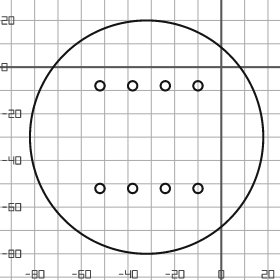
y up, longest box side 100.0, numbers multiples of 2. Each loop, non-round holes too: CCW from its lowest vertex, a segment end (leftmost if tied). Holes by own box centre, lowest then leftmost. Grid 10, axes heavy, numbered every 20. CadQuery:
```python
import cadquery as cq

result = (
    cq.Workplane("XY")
    .moveTo(-32.0, -30.0)
    .circle(50.0)
    .moveTo(-52.0, -52.0)
    .circle(2.0)
    .moveTo(-38.0, -52.0)
    .circle(2.0)
    .moveTo(-24.0, -52.0)
    .circle(2.0)
    .moveTo(-10.0, -52.0)
    .circle(2.0)
    .moveTo(-52.0, -8.0)
    .circle(2.0)
    .moveTo(-38.0, -8.0)
    .circle(2.0)
    .moveTo(-24.0, -8.0)
    .circle(2.0)
    .moveTo(-10.0, -8.0)
    .circle(2.0)
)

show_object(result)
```